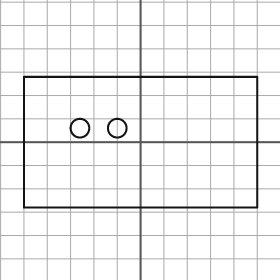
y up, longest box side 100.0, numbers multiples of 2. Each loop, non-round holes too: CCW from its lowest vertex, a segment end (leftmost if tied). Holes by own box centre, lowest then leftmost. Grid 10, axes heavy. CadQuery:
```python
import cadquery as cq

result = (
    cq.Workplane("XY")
    .moveTo(-50.0, -28.0)
    .lineTo(50.0, -28.0)
    .lineTo(50.0, 28.0)
    .lineTo(-50.0, 28.0)
    .close()
    .moveTo(-26.0, 6.0)
    .circle(4.0)
    .moveTo(-10.0, 6.0)
    .circle(4.0)
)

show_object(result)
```